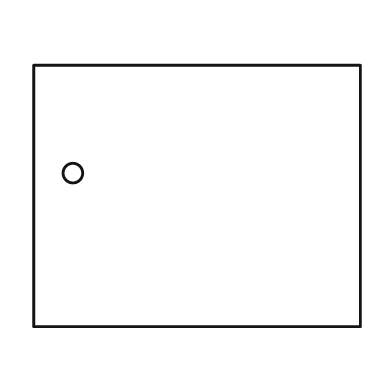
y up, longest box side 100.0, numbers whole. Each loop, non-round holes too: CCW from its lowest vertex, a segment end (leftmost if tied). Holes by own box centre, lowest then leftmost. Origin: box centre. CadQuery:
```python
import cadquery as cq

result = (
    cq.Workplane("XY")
    .moveTo(-50.0, -40.0)
    .lineTo(50.0, -40.0)
    .lineTo(50.0, 40.0)
    .lineTo(-50.0, 40.0)
    .close()
    .moveTo(-38.0, 7.0)
    .circle(3.0)
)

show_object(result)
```